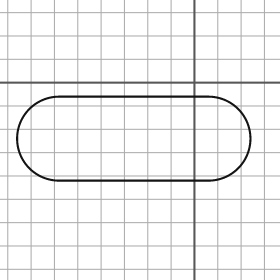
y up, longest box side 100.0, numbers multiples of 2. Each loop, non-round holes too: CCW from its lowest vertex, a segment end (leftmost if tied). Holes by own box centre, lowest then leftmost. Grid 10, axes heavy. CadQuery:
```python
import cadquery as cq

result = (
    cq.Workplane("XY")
    .moveTo(-58.0, -42.0)
    .lineTo(6.0, -42.0)
    .threePointArc((24.0, -24.0), (6.0, -6.0))
    .lineTo(-58.0, -6.0)
    .threePointArc((-76.0, -24.0), (-58.0, -42.0))
    .close()
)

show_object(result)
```